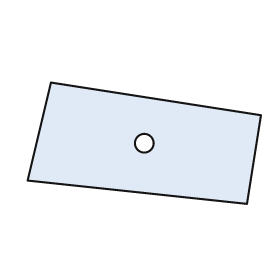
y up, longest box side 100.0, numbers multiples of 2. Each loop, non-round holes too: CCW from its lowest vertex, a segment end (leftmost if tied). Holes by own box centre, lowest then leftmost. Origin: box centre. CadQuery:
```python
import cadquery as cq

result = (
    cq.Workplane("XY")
    .moveTo(44.0, -26.0)
    .lineTo(50.0, 12.0)
    .lineTo(-40.0, 26.0)
    .lineTo(-50.0, -16.0)
    .close()
    .moveTo(0.0, 0.0)
    .circle(4.0)
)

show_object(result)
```